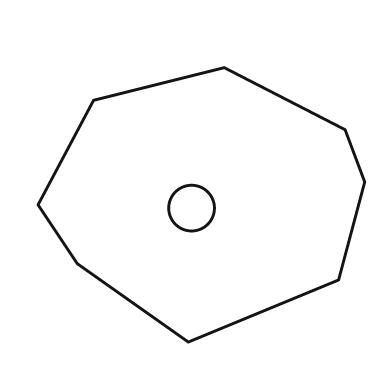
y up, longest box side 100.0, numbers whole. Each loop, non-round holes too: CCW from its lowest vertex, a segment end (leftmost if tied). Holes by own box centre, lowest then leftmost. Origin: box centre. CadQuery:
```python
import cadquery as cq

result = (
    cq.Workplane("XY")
    .moveTo(-4.0, -42.0)
    .lineTo(42.0, -23.0)
    .lineTo(50.0, 7.0)
    .lineTo(44.0, 23.0)
    .lineTo(7.0, 42.0)
    .lineTo(-33.0, 32.0)
    .lineTo(-50.0, 0.0)
    .lineTo(-38.0, -18.0)
    .close()
    .moveTo(-3.0, -1.0)
    .circle(7.0)
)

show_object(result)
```